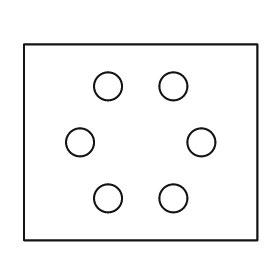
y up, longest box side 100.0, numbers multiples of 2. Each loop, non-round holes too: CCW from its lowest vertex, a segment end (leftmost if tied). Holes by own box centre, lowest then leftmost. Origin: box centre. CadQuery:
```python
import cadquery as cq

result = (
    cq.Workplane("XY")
    .moveTo(-50.0, -42.0)
    .lineTo(50.0, -42.0)
    .lineTo(50.0, 42.0)
    .lineTo(-50.0, 42.0)
    .close()
    .moveTo(-14.0, -24.0)
    .circle(6.0)
    .moveTo(14.0, -24.0)
    .circle(6.0)
    .moveTo(-26.0, 0.0)
    .circle(6.0)
    .moveTo(26.0, 0.0)
    .circle(6.0)
    .moveTo(-14.0, 24.0)
    .circle(6.0)
    .moveTo(14.0, 24.0)
    .circle(6.0)
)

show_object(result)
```